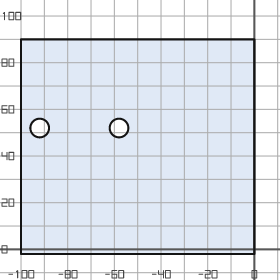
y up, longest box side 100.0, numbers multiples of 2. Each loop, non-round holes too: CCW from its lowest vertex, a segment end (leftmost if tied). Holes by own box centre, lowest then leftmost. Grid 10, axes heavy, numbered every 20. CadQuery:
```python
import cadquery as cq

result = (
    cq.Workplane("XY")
    .moveTo(-100.0, -2.0)
    .lineTo(0.0, -2.0)
    .lineTo(0.0, 90.0)
    .lineTo(-100.0, 90.0)
    .close()
    .moveTo(-92.0, 52.0)
    .circle(4.0)
    .moveTo(-58.0, 52.0)
    .circle(4.0)
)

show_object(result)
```